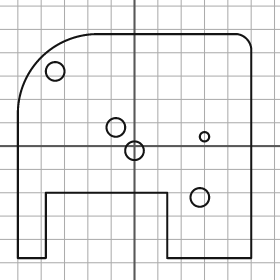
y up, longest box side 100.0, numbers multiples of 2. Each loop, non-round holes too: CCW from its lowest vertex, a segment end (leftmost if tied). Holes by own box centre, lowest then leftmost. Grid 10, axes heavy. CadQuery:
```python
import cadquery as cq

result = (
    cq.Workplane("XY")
    .moveTo(-50.0, -48.0)
    .lineTo(-38.0, -48.0)
    .lineTo(-38.0, -20.0)
    .lineTo(14.0, -20.0)
    .lineTo(14.0, -48.0)
    .lineTo(50.0, -48.0)
    .lineTo(50.0, 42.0)
    .threePointArc((48.0, 46.0), (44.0, 48.0))
    .lineTo(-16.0, 48.0)
    .threePointArc((-40.0, 38.0), (-50.0, 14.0))
    .close()
    .moveTo(28.0, -22.0)
    .circle(4.0)
    .moveTo(0.0, -2.0)
    .circle(4.0)
    .moveTo(30.0, 4.0)
    .circle(2.0)
    .moveTo(-8.0, 8.0)
    .circle(4.0)
    .moveTo(-34.0, 32.0)
    .circle(4.0)
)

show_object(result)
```